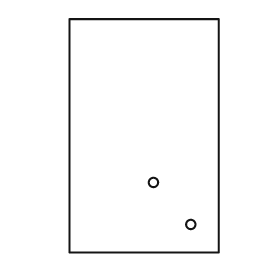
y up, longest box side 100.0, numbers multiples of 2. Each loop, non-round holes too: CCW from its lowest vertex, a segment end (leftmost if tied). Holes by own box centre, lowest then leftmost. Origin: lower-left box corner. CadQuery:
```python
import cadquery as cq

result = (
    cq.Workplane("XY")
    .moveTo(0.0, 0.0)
    .lineTo(64.0, 0.0)
    .lineTo(64.0, 100.0)
    .lineTo(0.0, 100.0)
    .close()
    .moveTo(52.0, 12.0)
    .circle(2.0)
    .moveTo(36.0, 30.0)
    .circle(2.0)
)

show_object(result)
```